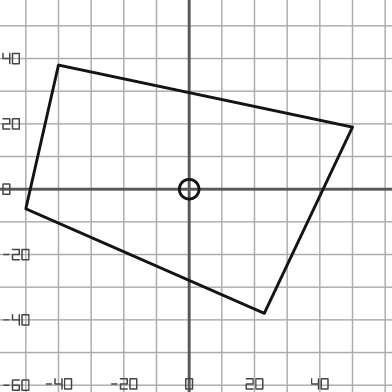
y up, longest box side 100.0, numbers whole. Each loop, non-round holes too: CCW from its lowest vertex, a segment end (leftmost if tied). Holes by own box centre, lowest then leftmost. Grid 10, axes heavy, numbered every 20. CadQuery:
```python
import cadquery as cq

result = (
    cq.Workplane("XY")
    .moveTo(23.0, -38.0)
    .lineTo(50.0, 19.0)
    .lineTo(-40.0, 38.0)
    .lineTo(-50.0, -6.0)
    .close()
    .moveTo(0.0, 0.0)
    .circle(3.0)
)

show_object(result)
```